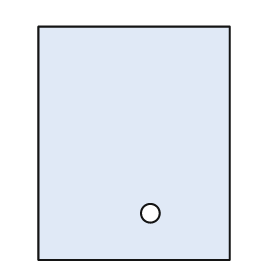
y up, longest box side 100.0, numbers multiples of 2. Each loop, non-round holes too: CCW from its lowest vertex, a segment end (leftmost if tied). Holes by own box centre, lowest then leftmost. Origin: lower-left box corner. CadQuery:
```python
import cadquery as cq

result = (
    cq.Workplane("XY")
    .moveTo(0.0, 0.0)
    .lineTo(82.0, 0.0)
    .lineTo(82.0, 100.0)
    .lineTo(0.0, 100.0)
    .close()
    .moveTo(48.0, 20.0)
    .circle(4.0)
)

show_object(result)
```